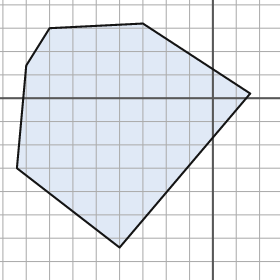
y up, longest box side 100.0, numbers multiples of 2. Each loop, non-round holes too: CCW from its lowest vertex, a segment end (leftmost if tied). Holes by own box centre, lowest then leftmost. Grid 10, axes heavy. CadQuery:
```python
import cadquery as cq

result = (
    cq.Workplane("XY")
    .moveTo(-40.0, -64.0)
    .lineTo(16.0, 2.0)
    .lineTo(-30.0, 32.0)
    .lineTo(-70.0, 30.0)
    .lineTo(-80.0, 14.0)
    .lineTo(-84.0, -30.0)
    .close()
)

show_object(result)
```